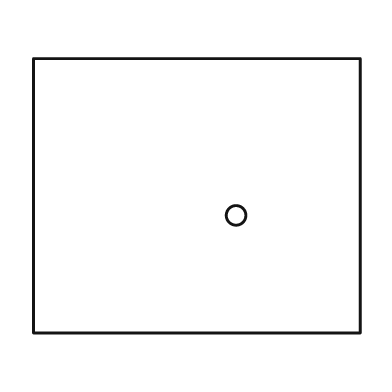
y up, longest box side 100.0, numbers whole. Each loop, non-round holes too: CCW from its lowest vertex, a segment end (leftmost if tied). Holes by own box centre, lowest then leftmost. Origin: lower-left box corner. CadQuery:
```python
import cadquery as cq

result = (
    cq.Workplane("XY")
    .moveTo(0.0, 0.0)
    .lineTo(100.0, 0.0)
    .lineTo(100.0, 84.0)
    .lineTo(0.0, 84.0)
    .close()
    .moveTo(62.0, 36.0)
    .circle(3.0)
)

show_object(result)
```